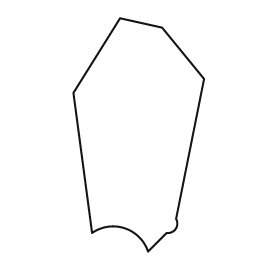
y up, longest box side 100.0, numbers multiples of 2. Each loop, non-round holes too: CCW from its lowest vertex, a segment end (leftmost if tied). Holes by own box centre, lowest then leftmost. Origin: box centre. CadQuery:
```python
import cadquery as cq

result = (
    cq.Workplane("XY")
    .moveTo(4.0, -50.0)
    .lineTo(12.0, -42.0)
    .threePointArc((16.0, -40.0), (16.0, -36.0))
    .lineTo(28.0, 24.0)
    .lineTo(10.0, 46.0)
    .lineTo(-8.0, 50.0)
    .lineTo(-28.0, 18.0)
    .lineTo(-20.0, -42.0)
    .threePointArc((-6.0, -40.0), (4.0, -50.0))
    .close()
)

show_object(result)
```